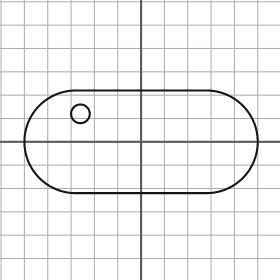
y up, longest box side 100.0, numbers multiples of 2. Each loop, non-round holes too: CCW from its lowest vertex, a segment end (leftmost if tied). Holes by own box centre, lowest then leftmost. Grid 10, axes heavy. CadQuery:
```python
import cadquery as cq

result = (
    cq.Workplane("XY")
    .moveTo(-28.0, -22.0)
    .lineTo(28.0, -22.0)
    .threePointArc((50.0, 0.0), (28.0, 22.0))
    .lineTo(-28.0, 22.0)
    .threePointArc((-50.0, 0.0), (-28.0, -22.0))
    .close()
    .moveTo(-26.0, 12.0)
    .circle(4.0)
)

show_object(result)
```